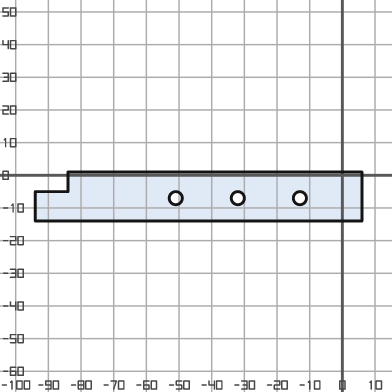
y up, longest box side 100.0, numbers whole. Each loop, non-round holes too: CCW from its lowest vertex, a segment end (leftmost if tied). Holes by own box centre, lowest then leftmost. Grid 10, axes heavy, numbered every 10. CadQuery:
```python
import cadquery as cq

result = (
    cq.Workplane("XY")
    .moveTo(-94.0, -14.0)
    .lineTo(6.0, -14.0)
    .lineTo(6.0, 1.0)
    .lineTo(-84.0, 1.0)
    .lineTo(-84.0, -5.0)
    .lineTo(-94.0, -5.0)
    .close()
    .moveTo(-51.0, -7.0)
    .circle(2.0)
    .moveTo(-32.0, -7.0)
    .circle(2.0)
    .moveTo(-13.0, -7.0)
    .circle(2.0)
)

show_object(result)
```